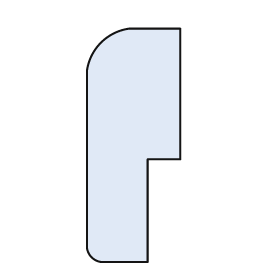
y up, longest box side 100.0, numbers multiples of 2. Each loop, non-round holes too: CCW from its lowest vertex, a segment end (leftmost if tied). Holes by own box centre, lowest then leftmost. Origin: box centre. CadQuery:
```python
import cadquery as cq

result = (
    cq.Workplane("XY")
    .moveTo(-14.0, -50.0)
    .lineTo(6.0, -50.0)
    .lineTo(6.0, -6.0)
    .lineTo(20.0, -6.0)
    .lineTo(20.0, 50.0)
    .lineTo(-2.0, 50.0)
    .threePointArc((-14.0, 44.0), (-20.0, 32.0))
    .lineTo(-20.0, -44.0)
    .threePointArc((-18.0, -48.0), (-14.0, -50.0))
    .close()
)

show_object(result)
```